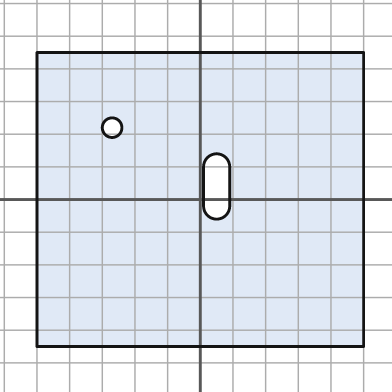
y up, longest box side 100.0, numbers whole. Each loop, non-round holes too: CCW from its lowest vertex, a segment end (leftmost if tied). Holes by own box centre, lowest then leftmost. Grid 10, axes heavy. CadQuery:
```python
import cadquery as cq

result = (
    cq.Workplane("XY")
    .moveTo(-50.0, -45.0)
    .lineTo(50.0, -45.0)
    .lineTo(50.0, 45.0)
    .lineTo(-50.0, 45.0)
    .close()
    .moveTo(1.0, -2.0)
    .threePointArc((5.0, -6.0), (9.0, -2.0))
    .lineTo(9.0, 10.0)
    .threePointArc((5.0, 14.0), (1.0, 10.0))
    .close()
    .moveTo(-27.0, 22.0)
    .circle(3.0)
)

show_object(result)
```